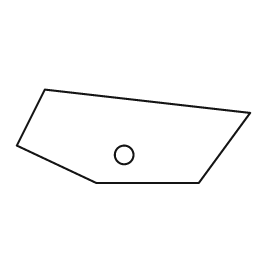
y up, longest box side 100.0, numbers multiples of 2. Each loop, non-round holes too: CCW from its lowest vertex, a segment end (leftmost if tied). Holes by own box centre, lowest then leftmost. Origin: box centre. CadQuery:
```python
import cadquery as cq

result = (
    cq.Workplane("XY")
    .moveTo(-16.0, -20.0)
    .lineTo(28.0, -20.0)
    .lineTo(50.0, 10.0)
    .lineTo(-38.0, 20.0)
    .lineTo(-50.0, -4.0)
    .close()
    .moveTo(-4.0, -8.0)
    .circle(4.0)
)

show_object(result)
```